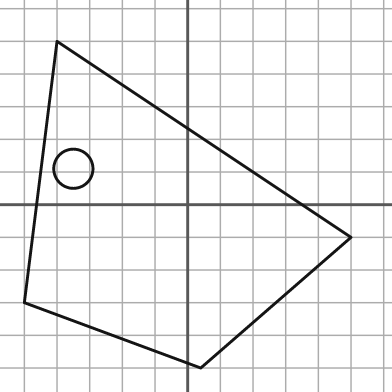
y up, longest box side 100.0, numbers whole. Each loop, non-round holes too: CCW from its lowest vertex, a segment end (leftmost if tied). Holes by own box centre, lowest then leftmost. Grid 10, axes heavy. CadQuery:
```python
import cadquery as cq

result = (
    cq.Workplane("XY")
    .moveTo(4.0, -50.0)
    .lineTo(50.0, -10.0)
    .lineTo(-40.0, 50.0)
    .lineTo(-50.0, -30.0)
    .close()
    .moveTo(-35.0, 11.0)
    .circle(6.0)
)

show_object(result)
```